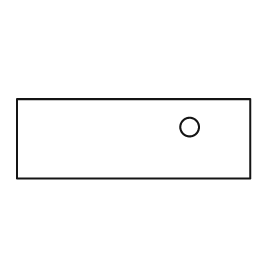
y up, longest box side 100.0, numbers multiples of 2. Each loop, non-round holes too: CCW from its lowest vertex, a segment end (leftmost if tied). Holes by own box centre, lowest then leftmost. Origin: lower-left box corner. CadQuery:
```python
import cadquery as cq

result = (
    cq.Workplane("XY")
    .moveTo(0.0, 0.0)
    .lineTo(100.0, 0.0)
    .lineTo(100.0, 34.0)
    .lineTo(0.0, 34.0)
    .close()
    .moveTo(74.0, 22.0)
    .circle(4.0)
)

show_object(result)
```